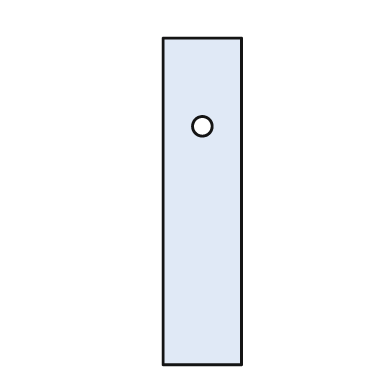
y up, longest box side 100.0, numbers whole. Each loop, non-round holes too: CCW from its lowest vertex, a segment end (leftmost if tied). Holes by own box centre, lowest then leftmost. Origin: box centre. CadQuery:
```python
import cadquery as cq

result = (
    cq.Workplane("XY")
    .moveTo(-12.0, -50.0)
    .lineTo(12.0, -50.0)
    .lineTo(12.0, 50.0)
    .lineTo(-12.0, 50.0)
    .close()
    .moveTo(0.0, 23.0)
    .circle(3.0)
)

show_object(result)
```